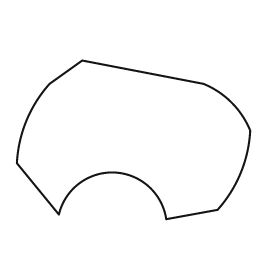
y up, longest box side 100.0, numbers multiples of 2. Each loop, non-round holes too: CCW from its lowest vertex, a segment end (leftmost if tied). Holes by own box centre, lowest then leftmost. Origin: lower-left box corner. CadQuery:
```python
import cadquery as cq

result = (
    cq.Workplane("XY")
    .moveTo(64.0, 0.0)
    .lineTo(86.0, 4.0)
    .threePointArc((96.0, 20.0), (100.0, 38.0))
    .threePointArc((92.0, 50.0), (80.0, 58.0))
    .lineTo(28.0, 68.0)
    .lineTo(14.0, 58.0)
    .threePointArc((4.0, 42.0), (0.0, 24.0))
    .lineTo(18.0, 2.0)
    .threePointArc((42.0, 20.0), (64.0, 0.0))
    .close()
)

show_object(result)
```